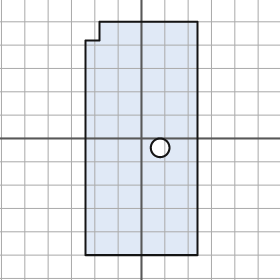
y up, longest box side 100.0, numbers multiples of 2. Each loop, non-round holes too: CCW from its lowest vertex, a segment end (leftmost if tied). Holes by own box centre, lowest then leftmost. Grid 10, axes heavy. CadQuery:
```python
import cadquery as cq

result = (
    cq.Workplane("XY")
    .moveTo(-24.0, -50.0)
    .lineTo(24.0, -50.0)
    .lineTo(24.0, 50.0)
    .lineTo(-18.0, 50.0)
    .lineTo(-18.0, 42.0)
    .lineTo(-24.0, 42.0)
    .close()
    .moveTo(8.0, -4.0)
    .circle(4.0)
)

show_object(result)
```